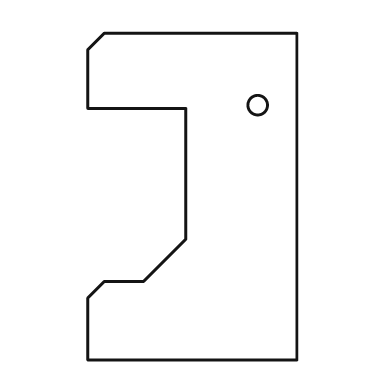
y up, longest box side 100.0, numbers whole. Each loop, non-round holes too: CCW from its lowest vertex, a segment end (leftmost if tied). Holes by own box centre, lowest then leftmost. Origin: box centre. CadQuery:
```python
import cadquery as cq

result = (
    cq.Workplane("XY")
    .moveTo(-32.0, -50.0)
    .lineTo(32.0, -50.0)
    .lineTo(32.0, 50.0)
    .lineTo(-27.0, 50.0)
    .lineTo(-32.0, 45.0)
    .lineTo(-32.0, 27.0)
    .lineTo(-2.0, 27.0)
    .lineTo(-2.0, -13.0)
    .lineTo(-15.0, -26.0)
    .lineTo(-27.0, -26.0)
    .lineTo(-32.0, -31.0)
    .close()
    .moveTo(20.0, 28.0)
    .circle(3.0)
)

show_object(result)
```